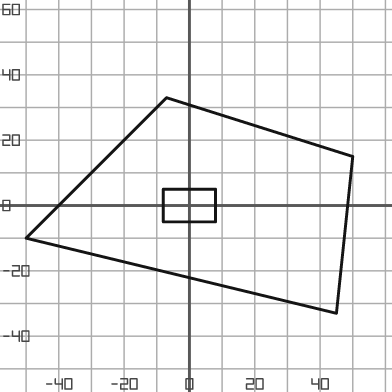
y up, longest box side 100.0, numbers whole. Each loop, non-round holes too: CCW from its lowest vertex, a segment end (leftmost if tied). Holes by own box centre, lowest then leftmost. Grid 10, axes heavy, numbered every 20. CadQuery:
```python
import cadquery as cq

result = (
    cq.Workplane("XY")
    .moveTo(45.0, -33.0)
    .lineTo(50.0, 15.0)
    .lineTo(-7.0, 33.0)
    .lineTo(-50.0, -10.0)
    .close()
    .moveTo(-8.0, -5.0)
    .lineTo(8.0, -5.0)
    .lineTo(8.0, 5.0)
    .lineTo(-8.0, 5.0)
    .close()
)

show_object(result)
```